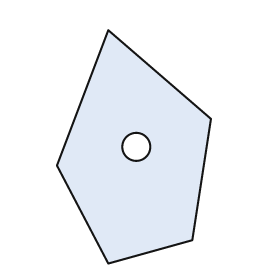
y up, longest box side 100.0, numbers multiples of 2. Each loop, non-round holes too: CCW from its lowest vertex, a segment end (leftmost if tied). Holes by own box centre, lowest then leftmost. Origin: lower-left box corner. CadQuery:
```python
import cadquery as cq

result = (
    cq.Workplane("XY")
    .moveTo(22.0, 0.0)
    .lineTo(58.0, 10.0)
    .lineTo(66.0, 62.0)
    .lineTo(22.0, 100.0)
    .lineTo(0.0, 42.0)
    .close()
    .moveTo(34.0, 50.0)
    .circle(6.0)
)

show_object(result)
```